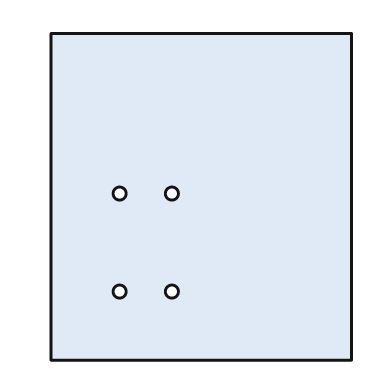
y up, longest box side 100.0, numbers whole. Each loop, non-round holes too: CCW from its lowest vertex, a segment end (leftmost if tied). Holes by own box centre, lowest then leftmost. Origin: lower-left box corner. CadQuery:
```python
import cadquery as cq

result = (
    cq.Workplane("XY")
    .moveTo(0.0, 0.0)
    .lineTo(92.0, 0.0)
    .lineTo(92.0, 100.0)
    .lineTo(0.0, 100.0)
    .close()
    .moveTo(21.0, 21.0)
    .circle(2.0)
    .moveTo(37.0, 21.0)
    .circle(2.0)
    .moveTo(21.0, 51.0)
    .circle(2.0)
    .moveTo(37.0, 51.0)
    .circle(2.0)
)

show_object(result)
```